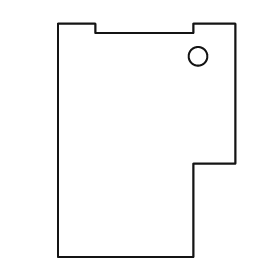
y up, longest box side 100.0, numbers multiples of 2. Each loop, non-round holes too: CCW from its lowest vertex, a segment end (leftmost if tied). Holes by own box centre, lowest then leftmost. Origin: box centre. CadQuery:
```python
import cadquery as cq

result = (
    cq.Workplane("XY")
    .moveTo(-38.0, -50.0)
    .lineTo(20.0, -50.0)
    .lineTo(20.0, -10.0)
    .lineTo(38.0, -10.0)
    .lineTo(38.0, 50.0)
    .lineTo(20.0, 50.0)
    .lineTo(20.0, 46.0)
    .lineTo(-22.0, 46.0)
    .lineTo(-22.0, 50.0)
    .lineTo(-38.0, 50.0)
    .close()
    .moveTo(22.0, 36.0)
    .circle(4.0)
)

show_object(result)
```